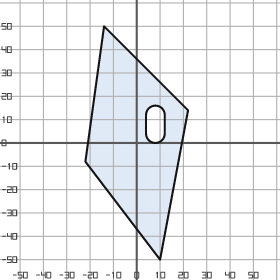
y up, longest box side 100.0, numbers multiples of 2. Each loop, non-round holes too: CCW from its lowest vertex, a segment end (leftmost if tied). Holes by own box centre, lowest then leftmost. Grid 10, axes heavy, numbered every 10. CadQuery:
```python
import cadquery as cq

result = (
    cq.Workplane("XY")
    .moveTo(10.0, -50.0)
    .lineTo(22.0, 14.0)
    .lineTo(-14.0, 50.0)
    .lineTo(-22.0, -8.0)
    .close()
    .moveTo(4.0, 4.0)
    .threePointArc((8.0, 0.0), (12.0, 4.0))
    .lineTo(12.0, 12.0)
    .threePointArc((8.0, 16.0), (4.0, 12.0))
    .close()
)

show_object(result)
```